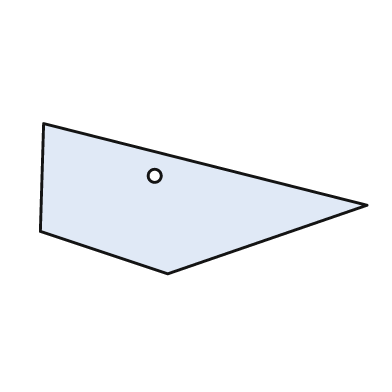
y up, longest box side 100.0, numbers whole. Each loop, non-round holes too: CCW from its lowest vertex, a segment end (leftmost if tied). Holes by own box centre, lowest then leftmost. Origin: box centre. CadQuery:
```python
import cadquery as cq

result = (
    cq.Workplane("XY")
    .moveTo(-11.0, -23.0)
    .lineTo(50.0, -2.0)
    .lineTo(-49.0, 23.0)
    .lineTo(-50.0, -10.0)
    .close()
    .moveTo(-15.0, 7.0)
    .circle(2.0)
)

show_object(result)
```